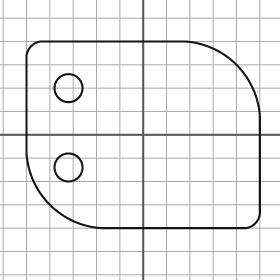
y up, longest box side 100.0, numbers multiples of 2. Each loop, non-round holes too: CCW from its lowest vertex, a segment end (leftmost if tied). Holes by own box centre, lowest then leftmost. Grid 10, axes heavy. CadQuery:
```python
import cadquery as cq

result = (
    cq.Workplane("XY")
    .moveTo(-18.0, -40.0)
    .lineTo(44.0, -40.0)
    .threePointArc((48.0, -38.0), (50.0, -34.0))
    .lineTo(50.0, 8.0)
    .threePointArc((40.0, 30.0), (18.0, 40.0))
    .lineTo(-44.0, 40.0)
    .threePointArc((-48.0, 38.0), (-50.0, 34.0))
    .lineTo(-50.0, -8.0)
    .threePointArc((-40.0, -30.0), (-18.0, -40.0))
    .close()
    .moveTo(-32.0, -14.0)
    .circle(6.0)
    .moveTo(-32.0, 20.0)
    .circle(6.0)
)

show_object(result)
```